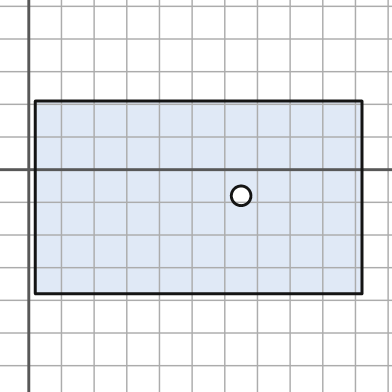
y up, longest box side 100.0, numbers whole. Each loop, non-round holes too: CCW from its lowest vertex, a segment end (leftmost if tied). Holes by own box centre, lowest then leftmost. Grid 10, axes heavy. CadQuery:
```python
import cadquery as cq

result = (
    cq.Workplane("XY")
    .moveTo(2.0, -38.0)
    .lineTo(102.0, -38.0)
    .lineTo(102.0, 21.0)
    .lineTo(2.0, 21.0)
    .close()
    .moveTo(65.0, -8.0)
    .circle(3.0)
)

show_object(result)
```